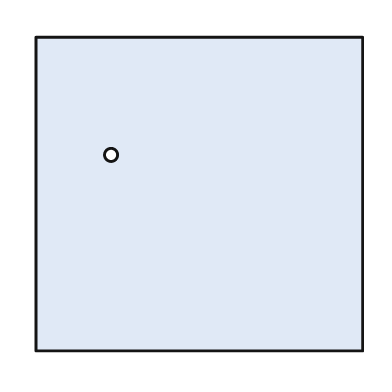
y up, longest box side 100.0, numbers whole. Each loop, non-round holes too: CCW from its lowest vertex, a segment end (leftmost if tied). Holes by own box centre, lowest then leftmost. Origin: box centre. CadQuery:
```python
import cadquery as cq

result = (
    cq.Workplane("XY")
    .moveTo(-50.0, -48.0)
    .lineTo(50.0, -48.0)
    .lineTo(50.0, 48.0)
    .lineTo(-50.0, 48.0)
    .close()
    .moveTo(-27.0, 12.0)
    .circle(2.0)
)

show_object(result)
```